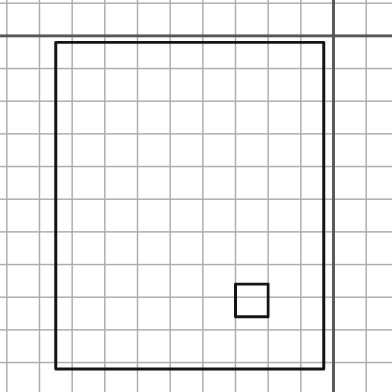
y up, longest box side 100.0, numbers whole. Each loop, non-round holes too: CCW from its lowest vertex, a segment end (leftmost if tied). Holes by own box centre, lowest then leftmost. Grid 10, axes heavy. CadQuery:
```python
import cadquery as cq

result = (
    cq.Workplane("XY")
    .moveTo(-85.0, -102.0)
    .lineTo(-3.0, -102.0)
    .lineTo(-3.0, -2.0)
    .lineTo(-85.0, -2.0)
    .close()
    .moveTo(-30.0, -86.0)
    .lineTo(-20.0, -86.0)
    .lineTo(-20.0, -76.0)
    .lineTo(-30.0, -76.0)
    .close()
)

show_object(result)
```